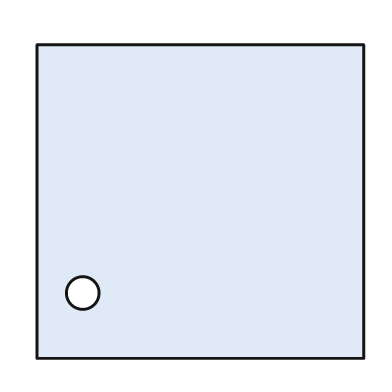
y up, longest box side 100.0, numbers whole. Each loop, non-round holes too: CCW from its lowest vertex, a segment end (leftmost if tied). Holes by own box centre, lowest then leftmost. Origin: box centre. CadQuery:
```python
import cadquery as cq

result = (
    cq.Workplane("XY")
    .moveTo(-50.0, -48.0)
    .lineTo(50.0, -48.0)
    .lineTo(50.0, 48.0)
    .lineTo(-50.0, 48.0)
    .close()
    .moveTo(-36.0, -28.0)
    .circle(5.0)
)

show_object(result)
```